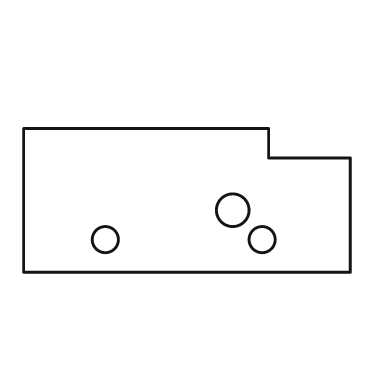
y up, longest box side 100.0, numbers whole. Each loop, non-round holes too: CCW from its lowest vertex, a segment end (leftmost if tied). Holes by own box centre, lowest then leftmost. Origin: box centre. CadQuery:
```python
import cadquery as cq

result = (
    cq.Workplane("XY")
    .moveTo(-50.0, -22.0)
    .lineTo(50.0, -22.0)
    .lineTo(50.0, 13.0)
    .lineTo(25.0, 13.0)
    .lineTo(25.0, 22.0)
    .lineTo(-50.0, 22.0)
    .close()
    .moveTo(-25.0, -12.0)
    .circle(4.0)
    .moveTo(23.0, -12.0)
    .circle(4.0)
    .moveTo(14.0, -3.0)
    .circle(5.0)
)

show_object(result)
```